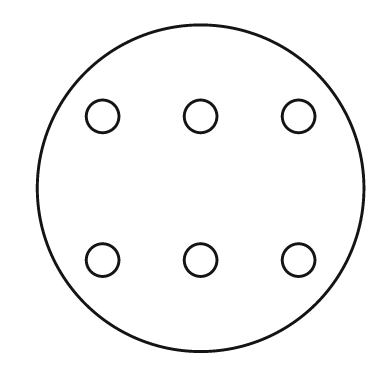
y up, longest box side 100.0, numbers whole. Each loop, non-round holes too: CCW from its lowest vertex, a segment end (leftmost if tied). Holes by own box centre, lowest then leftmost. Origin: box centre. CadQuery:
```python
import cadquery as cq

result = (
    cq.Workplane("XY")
    .moveTo(0.0, 0.0)
    .circle(50.0)
    .moveTo(-30.0, -22.0)
    .circle(5.0)
    .moveTo(0.0, -22.0)
    .circle(5.0)
    .moveTo(30.0, -22.0)
    .circle(5.0)
    .moveTo(-30.0, 22.0)
    .circle(5.0)
    .moveTo(0.0, 22.0)
    .circle(5.0)
    .moveTo(30.0, 22.0)
    .circle(5.0)
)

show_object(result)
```